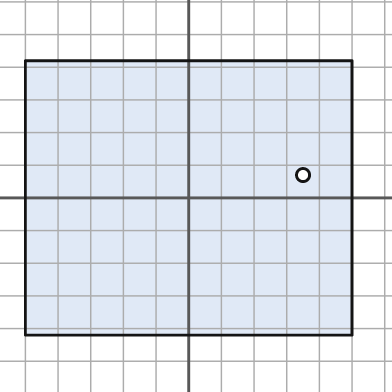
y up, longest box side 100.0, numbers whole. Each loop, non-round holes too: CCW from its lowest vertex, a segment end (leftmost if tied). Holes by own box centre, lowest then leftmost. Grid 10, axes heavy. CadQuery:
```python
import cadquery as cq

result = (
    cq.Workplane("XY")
    .moveTo(-50.0, -42.0)
    .lineTo(50.0, -42.0)
    .lineTo(50.0, 42.0)
    .lineTo(-50.0, 42.0)
    .close()
    .moveTo(35.0, 7.0)
    .circle(2.0)
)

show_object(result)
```